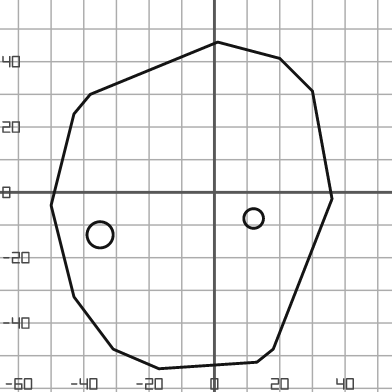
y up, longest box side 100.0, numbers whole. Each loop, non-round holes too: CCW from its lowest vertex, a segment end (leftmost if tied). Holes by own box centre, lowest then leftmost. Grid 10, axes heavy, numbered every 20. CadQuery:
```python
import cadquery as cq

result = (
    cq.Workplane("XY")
    .moveTo(-17.0, -54.0)
    .lineTo(13.0, -52.0)
    .lineTo(18.0, -48.0)
    .lineTo(36.0, -2.0)
    .lineTo(30.0, 31.0)
    .lineTo(20.0, 41.0)
    .lineTo(1.0, 46.0)
    .lineTo(-38.0, 30.0)
    .lineTo(-43.0, 24.0)
    .lineTo(-50.0, -4.0)
    .lineTo(-43.0, -32.0)
    .lineTo(-31.0, -48.0)
    .close()
    .moveTo(-35.0, -13.0)
    .circle(4.0)
    .moveTo(12.0, -8.0)
    .circle(3.0)
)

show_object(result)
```